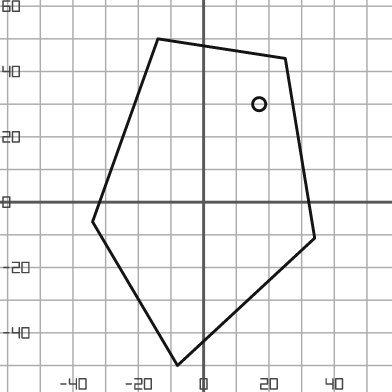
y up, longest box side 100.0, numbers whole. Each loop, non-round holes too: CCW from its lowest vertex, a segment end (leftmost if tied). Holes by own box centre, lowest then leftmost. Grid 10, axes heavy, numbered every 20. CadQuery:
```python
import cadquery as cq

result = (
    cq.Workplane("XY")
    .moveTo(-8.0, -50.0)
    .lineTo(34.0, -11.0)
    .lineTo(25.0, 44.0)
    .lineTo(-14.0, 50.0)
    .lineTo(-34.0, -6.0)
    .close()
    .moveTo(17.0, 30.0)
    .circle(2.0)
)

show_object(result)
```